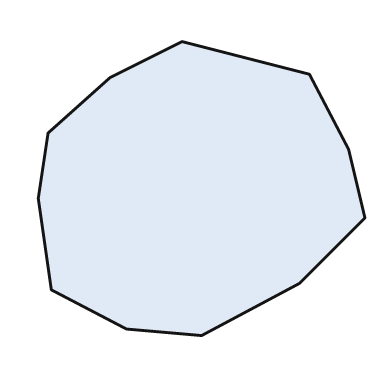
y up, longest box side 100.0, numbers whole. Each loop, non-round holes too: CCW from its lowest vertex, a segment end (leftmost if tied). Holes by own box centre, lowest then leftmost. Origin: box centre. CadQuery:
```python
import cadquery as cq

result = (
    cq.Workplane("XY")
    .moveTo(0.0, -45.0)
    .lineTo(30.0, -29.0)
    .lineTo(50.0, -9.0)
    .lineTo(45.0, 12.0)
    .lineTo(33.0, 35.0)
    .lineTo(-6.0, 45.0)
    .lineTo(-28.0, 34.0)
    .lineTo(-47.0, 17.0)
    .lineTo(-50.0, -3.0)
    .lineTo(-46.0, -31.0)
    .lineTo(-23.0, -43.0)
    .close()
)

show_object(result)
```